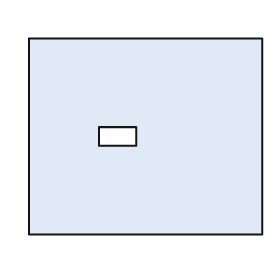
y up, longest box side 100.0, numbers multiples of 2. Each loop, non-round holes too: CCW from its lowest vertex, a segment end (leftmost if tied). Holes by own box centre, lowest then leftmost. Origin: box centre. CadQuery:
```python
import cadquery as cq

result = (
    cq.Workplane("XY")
    .moveTo(-50.0, -42.0)
    .lineTo(50.0, -42.0)
    .lineTo(50.0, 42.0)
    .lineTo(-50.0, 42.0)
    .close()
    .moveTo(-20.0, -4.0)
    .lineTo(-4.0, -4.0)
    .lineTo(-4.0, 4.0)
    .lineTo(-20.0, 4.0)
    .close()
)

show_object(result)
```